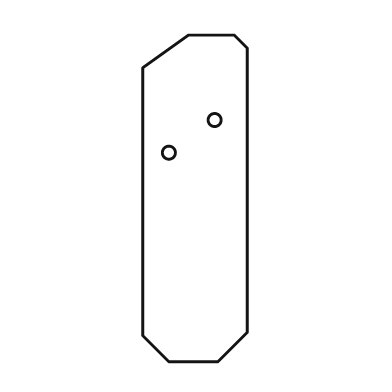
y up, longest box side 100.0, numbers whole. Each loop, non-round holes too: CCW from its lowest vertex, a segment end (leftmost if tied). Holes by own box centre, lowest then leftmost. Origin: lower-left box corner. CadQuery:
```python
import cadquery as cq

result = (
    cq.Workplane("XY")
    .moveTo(8.0, 0.0)
    .lineTo(23.0, 0.0)
    .lineTo(32.0, 9.0)
    .lineTo(32.0, 96.0)
    .lineTo(28.0, 100.0)
    .lineTo(14.0, 100.0)
    .lineTo(0.0, 90.0)
    .lineTo(0.0, 8.0)
    .close()
    .moveTo(8.0, 64.0)
    .circle(2.0)
    .moveTo(22.0, 74.0)
    .circle(2.0)
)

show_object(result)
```